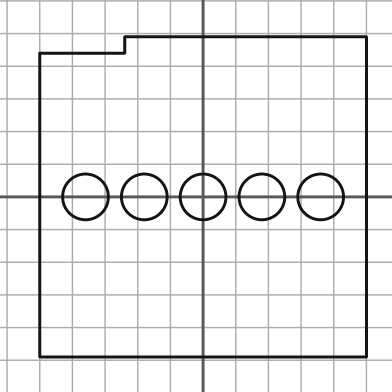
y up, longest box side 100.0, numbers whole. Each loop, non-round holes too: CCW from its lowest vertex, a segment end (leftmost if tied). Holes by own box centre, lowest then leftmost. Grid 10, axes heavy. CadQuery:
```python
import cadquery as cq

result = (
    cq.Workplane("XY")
    .moveTo(-50.0, -49.0)
    .lineTo(50.0, -49.0)
    .lineTo(50.0, 49.0)
    .lineTo(-24.0, 49.0)
    .lineTo(-24.0, 44.0)
    .lineTo(-50.0, 44.0)
    .close()
    .moveTo(-36.0, 0.0)
    .circle(7.0)
    .moveTo(-18.0, 0.0)
    .circle(7.0)
    .moveTo(0.0, 0.0)
    .circle(7.0)
    .moveTo(18.0, 0.0)
    .circle(7.0)
    .moveTo(36.0, 0.0)
    .circle(7.0)
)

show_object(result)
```